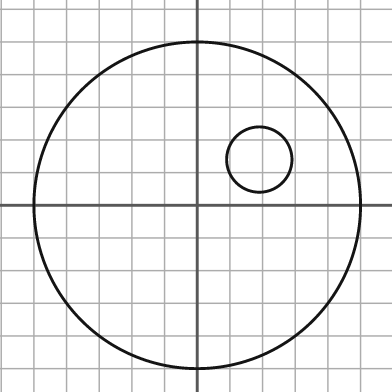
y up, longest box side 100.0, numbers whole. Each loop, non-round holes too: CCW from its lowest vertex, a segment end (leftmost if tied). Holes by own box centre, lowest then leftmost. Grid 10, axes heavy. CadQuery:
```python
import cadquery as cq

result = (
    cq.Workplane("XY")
    .moveTo(0.0, 0.0)
    .circle(50.0)
    .moveTo(19.0, 14.0)
    .circle(10.0)
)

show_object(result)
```